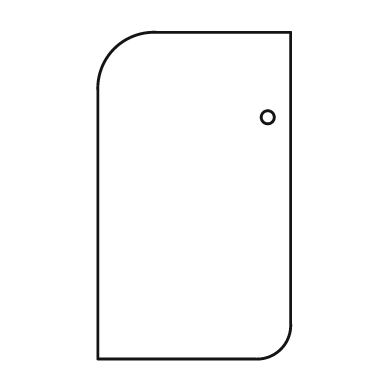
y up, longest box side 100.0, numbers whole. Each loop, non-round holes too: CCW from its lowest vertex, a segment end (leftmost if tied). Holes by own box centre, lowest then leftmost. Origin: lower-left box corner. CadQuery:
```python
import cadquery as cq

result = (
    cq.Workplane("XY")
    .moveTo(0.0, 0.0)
    .lineTo(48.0, 0.0)
    .threePointArc((56.0, 3.0), (59.0, 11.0))
    .lineTo(59.0, 100.0)
    .lineTo(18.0, 100.0)
    .threePointArc((5.0, 95.0), (0.0, 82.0))
    .close()
    .moveTo(52.0, 74.0)
    .circle(2.0)
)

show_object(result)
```